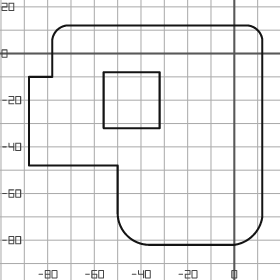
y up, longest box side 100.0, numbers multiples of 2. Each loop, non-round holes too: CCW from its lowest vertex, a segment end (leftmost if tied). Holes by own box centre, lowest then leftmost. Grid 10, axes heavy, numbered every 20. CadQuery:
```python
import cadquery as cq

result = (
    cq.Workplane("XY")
    .moveTo(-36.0, -82.0)
    .lineTo(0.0, -82.0)
    .threePointArc((8.0, -78.0), (12.0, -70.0))
    .lineTo(12.0, 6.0)
    .threePointArc((10.0, 10.0), (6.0, 12.0))
    .lineTo(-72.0, 12.0)
    .threePointArc((-76.0, 10.0), (-78.0, 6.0))
    .lineTo(-78.0, -10.0)
    .lineTo(-88.0, -10.0)
    .lineTo(-88.0, -48.0)
    .lineTo(-50.0, -48.0)
    .lineTo(-50.0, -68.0)
    .threePointArc((-46.0, -78.0), (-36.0, -82.0))
    .close()
    .moveTo(-56.0, -32.0)
    .lineTo(-32.0, -32.0)
    .lineTo(-32.0, -8.0)
    .lineTo(-56.0, -8.0)
    .close()
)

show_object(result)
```